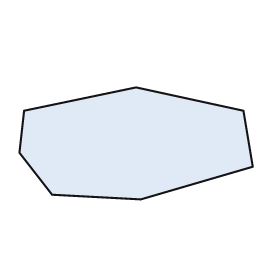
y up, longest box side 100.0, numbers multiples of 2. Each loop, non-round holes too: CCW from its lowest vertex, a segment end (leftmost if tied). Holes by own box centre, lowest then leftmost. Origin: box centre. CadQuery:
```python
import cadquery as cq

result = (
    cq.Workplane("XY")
    .moveTo(2.0, -24.0)
    .lineTo(50.0, -10.0)
    .lineTo(46.0, 14.0)
    .lineTo(0.0, 24.0)
    .lineTo(-48.0, 14.0)
    .lineTo(-50.0, -4.0)
    .lineTo(-36.0, -22.0)
    .close()
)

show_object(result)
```